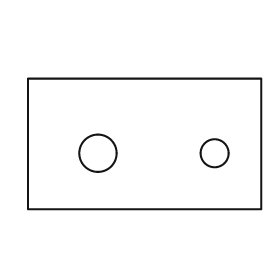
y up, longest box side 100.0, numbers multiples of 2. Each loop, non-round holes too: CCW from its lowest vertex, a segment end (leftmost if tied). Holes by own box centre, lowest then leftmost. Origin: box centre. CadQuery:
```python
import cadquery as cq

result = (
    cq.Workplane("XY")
    .moveTo(-50.0, -28.0)
    .lineTo(50.0, -28.0)
    .lineTo(50.0, 28.0)
    .lineTo(-50.0, 28.0)
    .close()
    .moveTo(-20.0, -4.0)
    .circle(8.0)
    .moveTo(30.0, -4.0)
    .circle(6.0)
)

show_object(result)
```